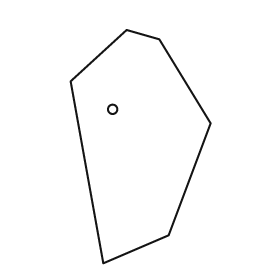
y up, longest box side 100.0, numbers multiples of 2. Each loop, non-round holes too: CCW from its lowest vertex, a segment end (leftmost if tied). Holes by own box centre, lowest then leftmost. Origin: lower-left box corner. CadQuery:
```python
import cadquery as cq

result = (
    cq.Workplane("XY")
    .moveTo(14.0, 0.0)
    .lineTo(42.0, 12.0)
    .lineTo(60.0, 60.0)
    .lineTo(38.0, 96.0)
    .lineTo(24.0, 100.0)
    .lineTo(0.0, 78.0)
    .close()
    .moveTo(18.0, 66.0)
    .circle(2.0)
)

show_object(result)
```